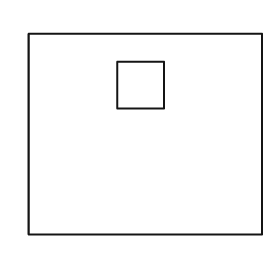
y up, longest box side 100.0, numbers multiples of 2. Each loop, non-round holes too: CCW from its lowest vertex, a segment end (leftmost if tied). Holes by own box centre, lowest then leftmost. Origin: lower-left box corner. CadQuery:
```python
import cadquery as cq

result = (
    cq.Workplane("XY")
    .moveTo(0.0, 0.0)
    .lineTo(100.0, 0.0)
    .lineTo(100.0, 86.0)
    .lineTo(0.0, 86.0)
    .close()
    .moveTo(38.0, 54.0)
    .lineTo(58.0, 54.0)
    .lineTo(58.0, 74.0)
    .lineTo(38.0, 74.0)
    .close()
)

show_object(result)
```